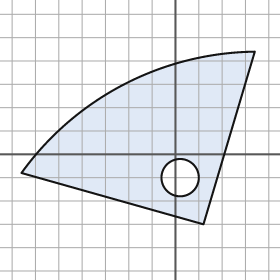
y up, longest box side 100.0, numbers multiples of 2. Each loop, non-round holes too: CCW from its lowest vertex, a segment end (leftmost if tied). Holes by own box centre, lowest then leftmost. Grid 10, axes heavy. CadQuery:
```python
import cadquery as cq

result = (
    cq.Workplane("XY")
    .moveTo(12.0, -30.0)
    .lineTo(34.0, 44.0)
    .threePointArc((-22.0, 30.0), (-66.0, -8.0))
    .close()
    .moveTo(2.0, -10.0)
    .circle(8.0)
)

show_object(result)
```